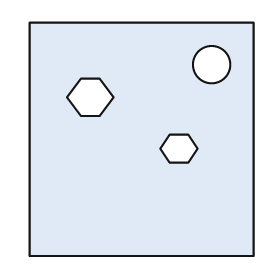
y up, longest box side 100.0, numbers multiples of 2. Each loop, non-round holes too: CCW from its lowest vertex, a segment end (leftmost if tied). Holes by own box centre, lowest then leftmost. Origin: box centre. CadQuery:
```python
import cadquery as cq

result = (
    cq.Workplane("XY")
    .moveTo(-48.0, -50.0)
    .lineTo(48.0, -50.0)
    .lineTo(48.0, 50.0)
    .lineTo(-48.0, 50.0)
    .close()
    .moveTo(12.0, -10.0)
    .lineTo(20.0, -10.0)
    .lineTo(24.0, -4.0)
    .lineTo(20.0, 2.0)
    .lineTo(12.0, 2.0)
    .lineTo(8.0, -4.0)
    .close()
    .moveTo(-26.0, 10.0)
    .lineTo(-18.0, 10.0)
    .lineTo(-12.0, 18.0)
    .lineTo(-18.0, 26.0)
    .lineTo(-26.0, 26.0)
    .lineTo(-32.0, 18.0)
    .close()
    .moveTo(30.0, 32.0)
    .circle(8.0)
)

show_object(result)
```